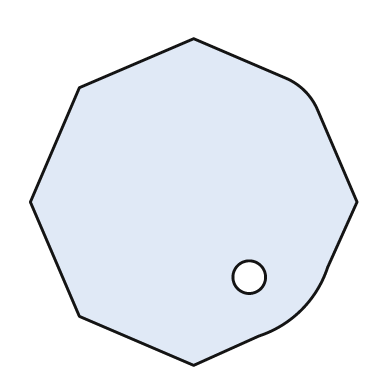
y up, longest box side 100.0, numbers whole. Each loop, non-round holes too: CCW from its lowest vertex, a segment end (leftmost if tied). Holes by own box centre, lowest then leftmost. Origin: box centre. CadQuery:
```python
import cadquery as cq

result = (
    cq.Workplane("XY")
    .moveTo(0.0, -50.0)
    .lineTo(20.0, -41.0)
    .threePointArc((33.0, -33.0), (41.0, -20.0))
    .lineTo(50.0, 0.0)
    .lineTo(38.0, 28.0)
    .threePointArc((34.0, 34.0), (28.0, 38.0))
    .lineTo(0.0, 50.0)
    .lineTo(-35.0, 35.0)
    .lineTo(-50.0, 0.0)
    .lineTo(-35.0, -35.0)
    .close()
    .moveTo(17.0, -23.0)
    .circle(5.0)
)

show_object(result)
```